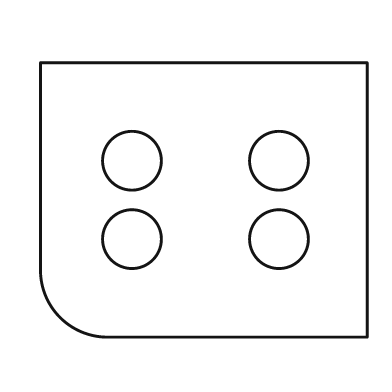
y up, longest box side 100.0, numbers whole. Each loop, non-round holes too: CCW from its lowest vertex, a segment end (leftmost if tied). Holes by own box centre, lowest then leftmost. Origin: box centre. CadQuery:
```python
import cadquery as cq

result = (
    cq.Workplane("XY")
    .moveTo(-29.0, -42.0)
    .lineTo(50.0, -42.0)
    .lineTo(50.0, 42.0)
    .lineTo(-50.0, 42.0)
    .lineTo(-50.0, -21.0)
    .threePointArc((-44.0, -36.0), (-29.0, -42.0))
    .close()
    .moveTo(-22.0, -12.0)
    .circle(9.0)
    .moveTo(23.0, -12.0)
    .circle(9.0)
    .moveTo(-22.0, 12.0)
    .circle(9.0)
    .moveTo(23.0, 12.0)
    .circle(9.0)
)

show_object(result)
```